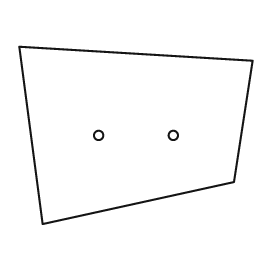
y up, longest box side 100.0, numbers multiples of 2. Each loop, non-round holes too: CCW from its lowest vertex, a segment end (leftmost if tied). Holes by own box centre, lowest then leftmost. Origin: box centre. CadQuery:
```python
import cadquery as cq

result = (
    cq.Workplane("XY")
    .moveTo(-40.0, -38.0)
    .lineTo(42.0, -20.0)
    .lineTo(50.0, 32.0)
    .lineTo(-50.0, 38.0)
    .close()
    .moveTo(-16.0, 0.0)
    .circle(2.0)
    .moveTo(16.0, 0.0)
    .circle(2.0)
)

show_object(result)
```